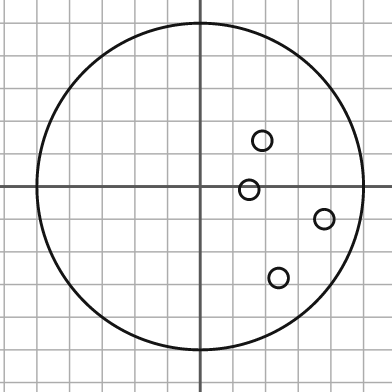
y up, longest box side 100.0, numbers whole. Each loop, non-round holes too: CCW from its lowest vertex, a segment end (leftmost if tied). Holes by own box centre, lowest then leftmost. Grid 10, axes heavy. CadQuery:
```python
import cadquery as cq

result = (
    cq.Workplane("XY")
    .moveTo(0.0, 0.0)
    .circle(50.0)
    .moveTo(24.0, -28.0)
    .circle(3.0)
    .moveTo(38.0, -10.0)
    .circle(3.0)
    .moveTo(15.0, -1.0)
    .circle(3.0)
    .moveTo(19.0, 14.0)
    .circle(3.0)
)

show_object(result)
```